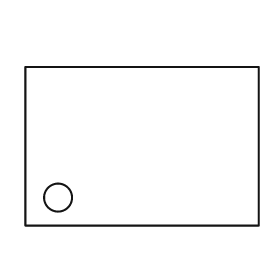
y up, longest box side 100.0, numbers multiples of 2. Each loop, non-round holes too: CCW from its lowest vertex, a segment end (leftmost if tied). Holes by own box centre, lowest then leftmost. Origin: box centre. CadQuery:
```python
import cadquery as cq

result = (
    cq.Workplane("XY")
    .moveTo(-50.0, -34.0)
    .lineTo(50.0, -34.0)
    .lineTo(50.0, 34.0)
    .lineTo(-50.0, 34.0)
    .close()
    .moveTo(-36.0, -22.0)
    .circle(6.0)
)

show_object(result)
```